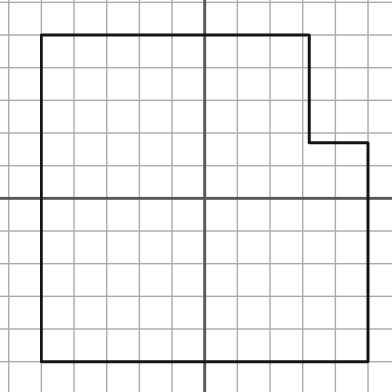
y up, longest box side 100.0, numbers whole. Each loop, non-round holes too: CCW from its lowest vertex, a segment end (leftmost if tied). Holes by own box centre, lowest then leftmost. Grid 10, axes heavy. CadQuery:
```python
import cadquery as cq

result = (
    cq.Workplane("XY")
    .moveTo(-50.0, -50.0)
    .lineTo(50.0, -50.0)
    .lineTo(50.0, 17.0)
    .lineTo(32.0, 17.0)
    .lineTo(32.0, 50.0)
    .lineTo(-50.0, 50.0)
    .close()
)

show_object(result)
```